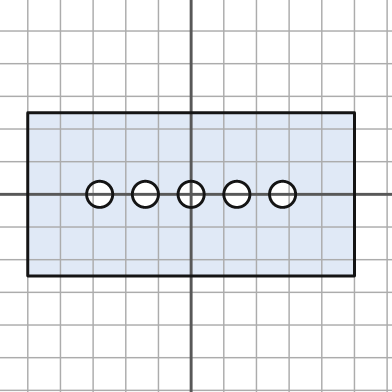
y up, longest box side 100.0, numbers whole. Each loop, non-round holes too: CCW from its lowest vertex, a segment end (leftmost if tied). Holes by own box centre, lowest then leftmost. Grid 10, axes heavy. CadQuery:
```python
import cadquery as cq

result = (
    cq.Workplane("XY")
    .moveTo(-50.0, -25.0)
    .lineTo(50.0, -25.0)
    .lineTo(50.0, 25.0)
    .lineTo(-50.0, 25.0)
    .close()
    .moveTo(-28.0, 0.0)
    .circle(4.0)
    .moveTo(-14.0, 0.0)
    .circle(4.0)
    .moveTo(0.0, 0.0)
    .circle(4.0)
    .moveTo(14.0, 0.0)
    .circle(4.0)
    .moveTo(28.0, 0.0)
    .circle(4.0)
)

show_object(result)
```